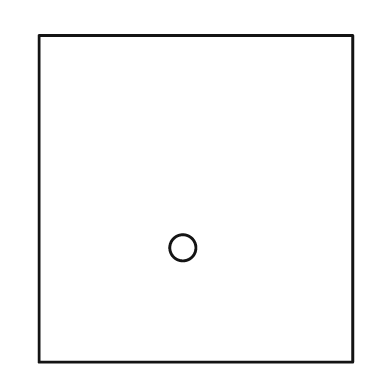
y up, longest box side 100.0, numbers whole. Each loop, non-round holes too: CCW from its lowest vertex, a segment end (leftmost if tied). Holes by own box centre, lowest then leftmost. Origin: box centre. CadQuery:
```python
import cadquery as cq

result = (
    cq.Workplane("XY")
    .moveTo(-48.0, -50.0)
    .lineTo(48.0, -50.0)
    .lineTo(48.0, 50.0)
    .lineTo(-48.0, 50.0)
    .close()
    .moveTo(-4.0, -15.0)
    .circle(4.0)
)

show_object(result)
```